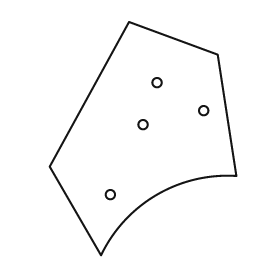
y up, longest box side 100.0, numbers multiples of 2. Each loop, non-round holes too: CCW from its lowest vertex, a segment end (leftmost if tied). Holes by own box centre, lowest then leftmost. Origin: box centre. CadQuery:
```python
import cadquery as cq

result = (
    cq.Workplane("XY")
    .moveTo(-18.0, -50.0)
    .threePointArc((6.0, -24.0), (40.0, -16.0))
    .lineTo(32.0, 36.0)
    .lineTo(-6.0, 50.0)
    .lineTo(-40.0, -12.0)
    .close()
    .moveTo(-14.0, -24.0)
    .circle(2.0)
    .moveTo(0.0, 6.0)
    .circle(2.0)
    .moveTo(26.0, 12.0)
    .circle(2.0)
    .moveTo(6.0, 24.0)
    .circle(2.0)
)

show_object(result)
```